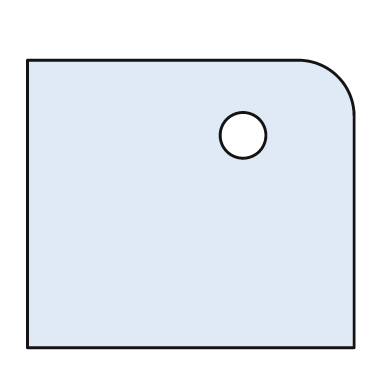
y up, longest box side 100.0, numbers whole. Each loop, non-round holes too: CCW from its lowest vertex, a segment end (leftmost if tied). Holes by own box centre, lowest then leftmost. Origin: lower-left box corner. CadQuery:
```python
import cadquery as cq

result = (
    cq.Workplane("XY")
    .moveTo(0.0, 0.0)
    .lineTo(100.0, 0.0)
    .lineTo(100.0, 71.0)
    .threePointArc((95.0, 83.0), (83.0, 88.0))
    .lineTo(0.0, 88.0)
    .close()
    .moveTo(66.0, 65.0)
    .circle(7.0)
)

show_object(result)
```